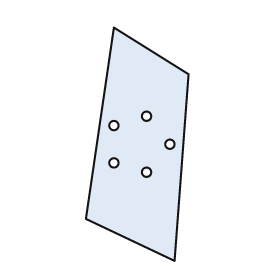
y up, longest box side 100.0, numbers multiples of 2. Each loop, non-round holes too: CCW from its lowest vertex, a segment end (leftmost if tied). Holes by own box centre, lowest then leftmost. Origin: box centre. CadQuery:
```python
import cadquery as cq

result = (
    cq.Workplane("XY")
    .moveTo(16.0, -50.0)
    .lineTo(22.0, 30.0)
    .lineTo(-10.0, 50.0)
    .lineTo(-22.0, -32.0)
    .close()
    .moveTo(4.0, -12.0)
    .circle(2.0)
    .moveTo(-10.0, -8.0)
    .circle(2.0)
    .moveTo(14.0, 0.0)
    .circle(2.0)
    .moveTo(-10.0, 8.0)
    .circle(2.0)
    .moveTo(4.0, 12.0)
    .circle(2.0)
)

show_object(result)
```